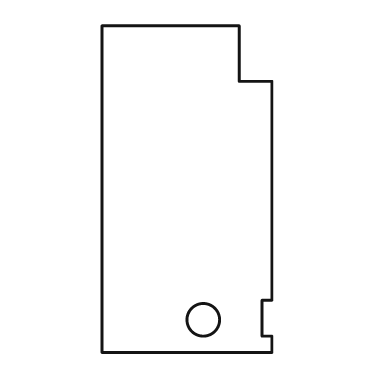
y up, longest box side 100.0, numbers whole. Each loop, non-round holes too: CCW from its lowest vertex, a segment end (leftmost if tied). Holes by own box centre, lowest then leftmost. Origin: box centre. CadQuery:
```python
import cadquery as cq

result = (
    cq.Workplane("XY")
    .moveTo(-26.0, -50.0)
    .lineTo(26.0, -50.0)
    .lineTo(26.0, -45.0)
    .lineTo(23.0, -45.0)
    .lineTo(23.0, -34.0)
    .lineTo(26.0, -34.0)
    .lineTo(26.0, 33.0)
    .lineTo(16.0, 33.0)
    .lineTo(16.0, 50.0)
    .lineTo(-26.0, 50.0)
    .close()
    .moveTo(5.0, -40.0)
    .circle(5.0)
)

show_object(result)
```